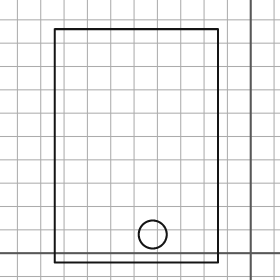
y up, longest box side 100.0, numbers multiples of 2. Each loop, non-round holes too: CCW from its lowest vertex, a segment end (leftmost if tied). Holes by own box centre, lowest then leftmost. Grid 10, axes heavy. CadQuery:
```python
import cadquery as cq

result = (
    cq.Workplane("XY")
    .moveTo(-84.0, -4.0)
    .lineTo(-14.0, -4.0)
    .lineTo(-14.0, 96.0)
    .lineTo(-84.0, 96.0)
    .close()
    .moveTo(-42.0, 8.0)
    .circle(6.0)
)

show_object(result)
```